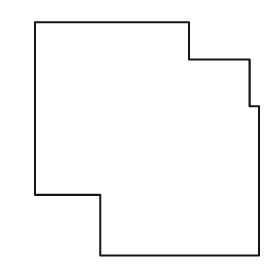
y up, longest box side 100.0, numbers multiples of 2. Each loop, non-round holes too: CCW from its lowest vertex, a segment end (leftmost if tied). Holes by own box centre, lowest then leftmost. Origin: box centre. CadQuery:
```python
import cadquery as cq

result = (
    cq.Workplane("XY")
    .moveTo(-20.0, -50.0)
    .lineTo(48.0, -50.0)
    .lineTo(48.0, 14.0)
    .lineTo(44.0, 14.0)
    .lineTo(44.0, 34.0)
    .lineTo(18.0, 34.0)
    .lineTo(18.0, 50.0)
    .lineTo(-48.0, 50.0)
    .lineTo(-48.0, -24.0)
    .lineTo(-20.0, -24.0)
    .close()
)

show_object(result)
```